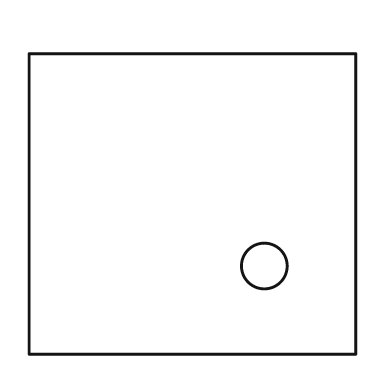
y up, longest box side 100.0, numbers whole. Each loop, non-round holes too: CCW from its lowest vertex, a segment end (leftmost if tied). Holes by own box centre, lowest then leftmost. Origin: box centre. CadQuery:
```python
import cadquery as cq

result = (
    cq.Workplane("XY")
    .moveTo(-50.0, -46.0)
    .lineTo(50.0, -46.0)
    .lineTo(50.0, 46.0)
    .lineTo(-50.0, 46.0)
    .close()
    .moveTo(22.0, -19.0)
    .circle(7.0)
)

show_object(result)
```